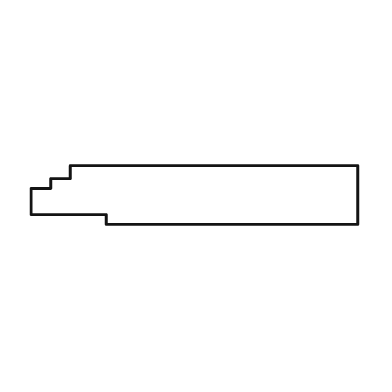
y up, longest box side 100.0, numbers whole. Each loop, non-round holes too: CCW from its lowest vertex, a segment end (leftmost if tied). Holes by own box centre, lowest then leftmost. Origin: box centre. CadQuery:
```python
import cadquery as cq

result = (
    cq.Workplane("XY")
    .moveTo(-27.0, -9.0)
    .lineTo(50.0, -9.0)
    .lineTo(50.0, 9.0)
    .lineTo(-38.0, 9.0)
    .lineTo(-38.0, 5.0)
    .lineTo(-44.0, 5.0)
    .lineTo(-44.0, 2.0)
    .lineTo(-50.0, 2.0)
    .lineTo(-50.0, -6.0)
    .lineTo(-27.0, -6.0)
    .close()
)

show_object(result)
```